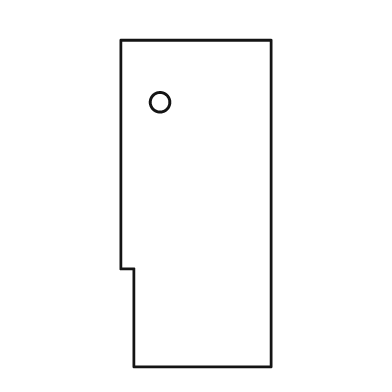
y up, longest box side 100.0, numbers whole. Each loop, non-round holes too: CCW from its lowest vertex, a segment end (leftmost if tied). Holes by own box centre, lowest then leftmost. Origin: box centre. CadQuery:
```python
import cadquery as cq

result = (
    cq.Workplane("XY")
    .moveTo(-19.0, -50.0)
    .lineTo(23.0, -50.0)
    .lineTo(23.0, 50.0)
    .lineTo(-23.0, 50.0)
    .lineTo(-23.0, -20.0)
    .lineTo(-19.0, -20.0)
    .close()
    .moveTo(-11.0, 31.0)
    .circle(3.0)
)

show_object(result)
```